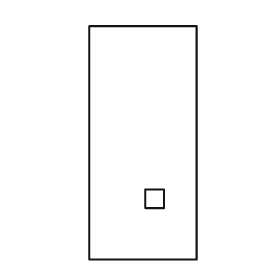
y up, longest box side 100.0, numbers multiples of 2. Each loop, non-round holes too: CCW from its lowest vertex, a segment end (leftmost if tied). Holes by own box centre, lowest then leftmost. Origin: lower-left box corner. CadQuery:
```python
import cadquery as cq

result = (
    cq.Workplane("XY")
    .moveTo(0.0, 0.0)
    .lineTo(46.0, 0.0)
    .lineTo(46.0, 100.0)
    .lineTo(0.0, 100.0)
    .close()
    .moveTo(24.0, 22.0)
    .lineTo(32.0, 22.0)
    .lineTo(32.0, 30.0)
    .lineTo(24.0, 30.0)
    .close()
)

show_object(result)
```